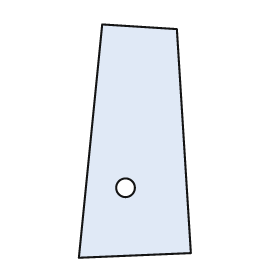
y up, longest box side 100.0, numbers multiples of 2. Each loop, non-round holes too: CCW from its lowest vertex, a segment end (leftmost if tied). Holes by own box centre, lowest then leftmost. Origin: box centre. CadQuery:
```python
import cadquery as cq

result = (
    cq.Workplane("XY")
    .moveTo(-24.0, -50.0)
    .lineTo(24.0, -48.0)
    .lineTo(18.0, 48.0)
    .lineTo(-14.0, 50.0)
    .close()
    .moveTo(-4.0, -20.0)
    .circle(4.0)
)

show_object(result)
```